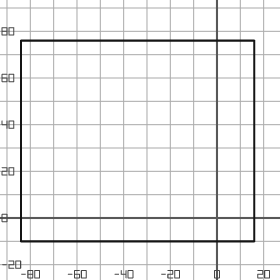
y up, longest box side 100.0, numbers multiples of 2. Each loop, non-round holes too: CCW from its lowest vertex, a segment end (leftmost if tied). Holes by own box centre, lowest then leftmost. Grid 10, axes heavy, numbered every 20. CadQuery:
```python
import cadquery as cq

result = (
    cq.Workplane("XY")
    .moveTo(-84.0, -10.0)
    .lineTo(16.0, -10.0)
    .lineTo(16.0, 76.0)
    .lineTo(-84.0, 76.0)
    .close()
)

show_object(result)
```